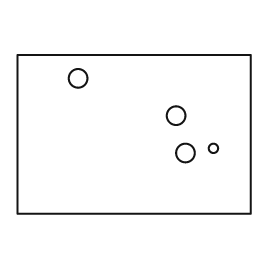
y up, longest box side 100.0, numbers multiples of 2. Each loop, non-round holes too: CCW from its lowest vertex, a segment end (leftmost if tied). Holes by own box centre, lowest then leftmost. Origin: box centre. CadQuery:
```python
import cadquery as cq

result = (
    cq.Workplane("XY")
    .moveTo(-50.0, -34.0)
    .lineTo(50.0, -34.0)
    .lineTo(50.0, 34.0)
    .lineTo(-50.0, 34.0)
    .close()
    .moveTo(22.0, -8.0)
    .circle(4.0)
    .moveTo(34.0, -6.0)
    .circle(2.0)
    .moveTo(18.0, 8.0)
    .circle(4.0)
    .moveTo(-24.0, 24.0)
    .circle(4.0)
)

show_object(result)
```